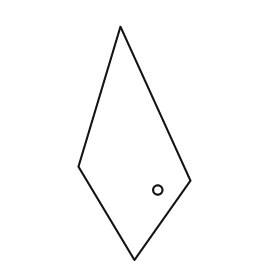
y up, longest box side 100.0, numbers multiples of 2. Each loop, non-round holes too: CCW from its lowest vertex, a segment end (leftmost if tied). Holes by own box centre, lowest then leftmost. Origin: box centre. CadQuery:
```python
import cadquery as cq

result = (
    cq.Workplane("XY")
    .moveTo(0.0, -50.0)
    .lineTo(24.0, -16.0)
    .lineTo(-6.0, 50.0)
    .lineTo(-24.0, -10.0)
    .close()
    .moveTo(10.0, -20.0)
    .circle(2.0)
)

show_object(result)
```